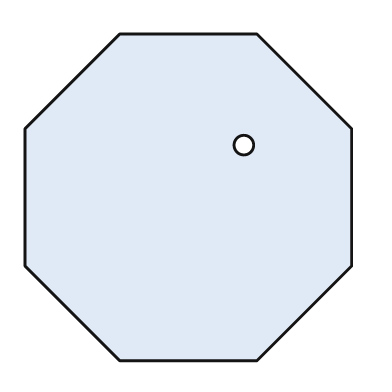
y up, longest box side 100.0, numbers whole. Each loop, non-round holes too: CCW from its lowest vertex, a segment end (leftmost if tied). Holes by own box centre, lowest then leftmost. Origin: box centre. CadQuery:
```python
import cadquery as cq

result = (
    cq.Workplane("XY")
    .moveTo(-21.0, -50.0)
    .lineTo(21.0, -50.0)
    .lineTo(50.0, -21.0)
    .lineTo(50.0, 21.0)
    .lineTo(21.0, 50.0)
    .lineTo(-21.0, 50.0)
    .lineTo(-50.0, 21.0)
    .lineTo(-50.0, -21.0)
    .close()
    .moveTo(17.0, 16.0)
    .circle(3.0)
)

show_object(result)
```